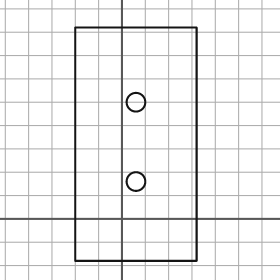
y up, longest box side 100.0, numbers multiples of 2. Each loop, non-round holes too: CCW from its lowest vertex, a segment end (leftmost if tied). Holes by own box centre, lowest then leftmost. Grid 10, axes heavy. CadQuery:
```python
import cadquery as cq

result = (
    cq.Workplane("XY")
    .moveTo(-20.0, -18.0)
    .lineTo(32.0, -18.0)
    .lineTo(32.0, 82.0)
    .lineTo(-20.0, 82.0)
    .close()
    .moveTo(6.0, 16.0)
    .circle(4.0)
    .moveTo(6.0, 50.0)
    .circle(4.0)
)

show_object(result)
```